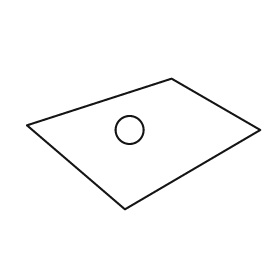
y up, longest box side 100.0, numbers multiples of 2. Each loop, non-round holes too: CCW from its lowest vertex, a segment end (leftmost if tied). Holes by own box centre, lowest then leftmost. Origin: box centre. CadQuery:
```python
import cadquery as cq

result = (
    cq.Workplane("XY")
    .moveTo(-8.0, -28.0)
    .lineTo(50.0, 6.0)
    .lineTo(12.0, 28.0)
    .lineTo(-50.0, 8.0)
    .close()
    .moveTo(-6.0, 6.0)
    .circle(6.0)
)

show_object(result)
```